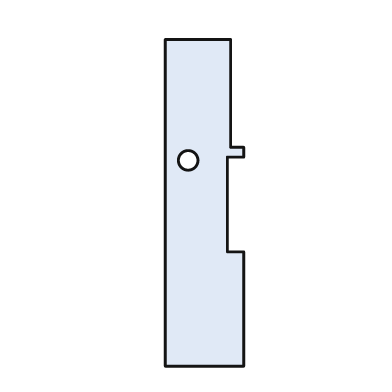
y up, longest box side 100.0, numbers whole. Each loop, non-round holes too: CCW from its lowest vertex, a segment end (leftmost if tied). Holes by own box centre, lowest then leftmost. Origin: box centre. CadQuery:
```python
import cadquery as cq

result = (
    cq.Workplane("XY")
    .moveTo(-12.0, -50.0)
    .lineTo(12.0, -50.0)
    .lineTo(12.0, -15.0)
    .lineTo(7.0, -15.0)
    .lineTo(7.0, 14.0)
    .lineTo(12.0, 14.0)
    .lineTo(12.0, 17.0)
    .lineTo(8.0, 17.0)
    .lineTo(8.0, 50.0)
    .lineTo(-12.0, 50.0)
    .close()
    .moveTo(-5.0, 13.0)
    .circle(3.0)
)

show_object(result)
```